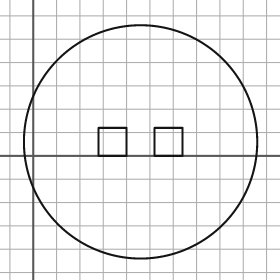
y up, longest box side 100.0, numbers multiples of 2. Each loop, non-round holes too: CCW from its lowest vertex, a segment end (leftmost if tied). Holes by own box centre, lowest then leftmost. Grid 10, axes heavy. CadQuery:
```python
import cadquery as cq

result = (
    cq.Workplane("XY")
    .moveTo(46.0, 6.0)
    .circle(50.0)
    .moveTo(28.0, 0.0)
    .lineTo(40.0, 0.0)
    .lineTo(40.0, 12.0)
    .lineTo(28.0, 12.0)
    .close()
    .moveTo(52.0, 0.0)
    .lineTo(64.0, 0.0)
    .lineTo(64.0, 12.0)
    .lineTo(52.0, 12.0)
    .close()
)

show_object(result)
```